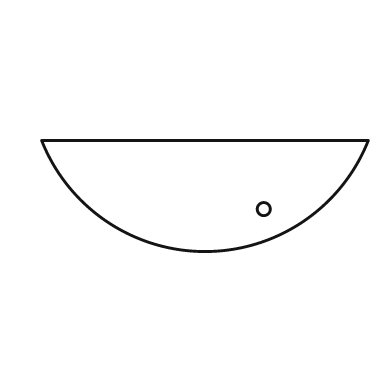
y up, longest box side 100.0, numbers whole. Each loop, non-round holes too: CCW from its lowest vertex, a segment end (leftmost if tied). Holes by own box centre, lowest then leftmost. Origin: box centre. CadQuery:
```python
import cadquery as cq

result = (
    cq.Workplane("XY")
    .moveTo(-50.0, 17.0)
    .threePointArc((0.0, -17.0), (50.0, 17.0))
    .close()
    .moveTo(18.0, -4.0)
    .circle(2.0)
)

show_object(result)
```